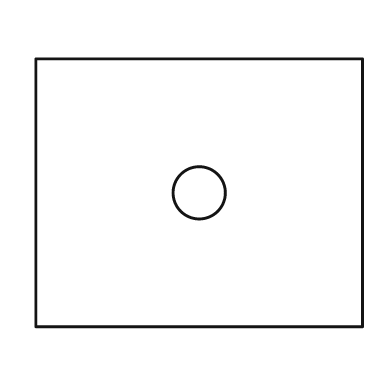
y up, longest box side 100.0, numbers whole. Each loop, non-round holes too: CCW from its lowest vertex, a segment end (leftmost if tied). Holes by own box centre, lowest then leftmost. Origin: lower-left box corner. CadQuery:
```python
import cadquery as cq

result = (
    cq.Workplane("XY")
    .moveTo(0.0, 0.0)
    .lineTo(100.0, 0.0)
    .lineTo(100.0, 82.0)
    .lineTo(0.0, 82.0)
    .close()
    .moveTo(50.0, 41.0)
    .circle(8.0)
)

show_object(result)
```